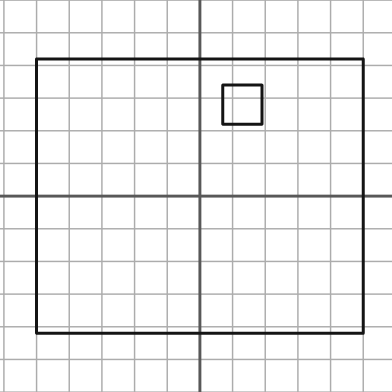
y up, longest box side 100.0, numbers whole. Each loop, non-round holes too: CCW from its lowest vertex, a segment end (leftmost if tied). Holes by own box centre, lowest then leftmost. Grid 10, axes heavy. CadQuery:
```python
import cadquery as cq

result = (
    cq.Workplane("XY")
    .moveTo(-50.0, -42.0)
    .lineTo(50.0, -42.0)
    .lineTo(50.0, 42.0)
    .lineTo(-50.0, 42.0)
    .close()
    .moveTo(7.0, 22.0)
    .lineTo(19.0, 22.0)
    .lineTo(19.0, 34.0)
    .lineTo(7.0, 34.0)
    .close()
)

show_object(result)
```